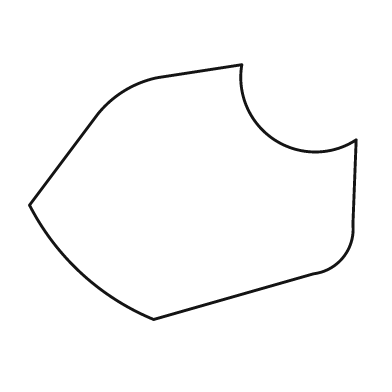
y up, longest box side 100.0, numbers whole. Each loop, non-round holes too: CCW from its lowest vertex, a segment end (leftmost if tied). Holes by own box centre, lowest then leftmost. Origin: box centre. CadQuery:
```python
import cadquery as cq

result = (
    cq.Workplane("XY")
    .moveTo(-12.0, -39.0)
    .lineTo(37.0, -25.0)
    .threePointArc((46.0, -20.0), (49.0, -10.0))
    .lineTo(50.0, 16.0)
    .threePointArc((25.0, 16.0), (15.0, 39.0))
    .lineTo(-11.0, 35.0)
    .threePointArc((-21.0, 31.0), (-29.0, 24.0))
    .lineTo(-50.0, -4.0)
    .threePointArc((-34.0, -25.0), (-12.0, -39.0))
    .close()
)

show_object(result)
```